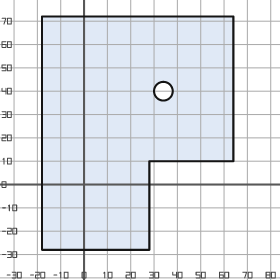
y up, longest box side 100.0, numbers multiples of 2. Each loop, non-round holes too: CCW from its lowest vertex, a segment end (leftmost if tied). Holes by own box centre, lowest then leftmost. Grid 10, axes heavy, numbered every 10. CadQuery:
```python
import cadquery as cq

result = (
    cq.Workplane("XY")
    .moveTo(-18.0, -28.0)
    .lineTo(28.0, -28.0)
    .lineTo(28.0, 10.0)
    .lineTo(64.0, 10.0)
    .lineTo(64.0, 72.0)
    .lineTo(-18.0, 72.0)
    .close()
    .moveTo(34.0, 40.0)
    .circle(4.0)
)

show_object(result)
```